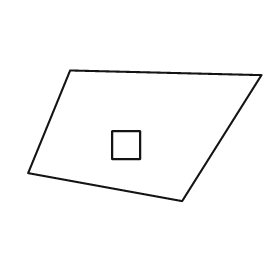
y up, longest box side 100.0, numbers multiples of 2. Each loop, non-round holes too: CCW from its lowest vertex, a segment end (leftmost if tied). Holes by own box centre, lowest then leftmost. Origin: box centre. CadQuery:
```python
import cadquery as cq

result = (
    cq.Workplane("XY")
    .moveTo(16.0, -28.0)
    .lineTo(50.0, 26.0)
    .lineTo(-32.0, 28.0)
    .lineTo(-50.0, -16.0)
    .close()
    .moveTo(-14.0, -10.0)
    .lineTo(-2.0, -10.0)
    .lineTo(-2.0, 2.0)
    .lineTo(-14.0, 2.0)
    .close()
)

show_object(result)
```